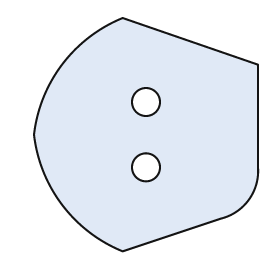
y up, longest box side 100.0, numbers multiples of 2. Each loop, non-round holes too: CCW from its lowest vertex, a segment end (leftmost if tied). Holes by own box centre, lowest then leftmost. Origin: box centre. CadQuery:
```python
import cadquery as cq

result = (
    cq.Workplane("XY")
    .moveTo(-10.0, -50.0)
    .lineTo(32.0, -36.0)
    .threePointArc((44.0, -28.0), (48.0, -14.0))
    .lineTo(48.0, 30.0)
    .lineTo(-10.0, 50.0)
    .threePointArc((-36.0, 30.0), (-48.0, 0.0))
    .threePointArc((-36.0, -30.0), (-10.0, -50.0))
    .close()
    .moveTo(0.0, -14.0)
    .circle(6.0)
    .moveTo(0.0, 14.0)
    .circle(6.0)
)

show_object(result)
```